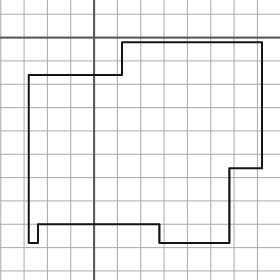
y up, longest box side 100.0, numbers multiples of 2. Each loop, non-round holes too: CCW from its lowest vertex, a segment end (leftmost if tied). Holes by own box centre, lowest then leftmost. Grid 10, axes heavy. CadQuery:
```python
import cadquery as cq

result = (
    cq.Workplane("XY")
    .moveTo(-28.0, -88.0)
    .lineTo(-24.0, -88.0)
    .lineTo(-24.0, -80.0)
    .lineTo(28.0, -80.0)
    .lineTo(28.0, -88.0)
    .lineTo(58.0, -88.0)
    .lineTo(58.0, -56.0)
    .lineTo(72.0, -56.0)
    .lineTo(72.0, -2.0)
    .lineTo(12.0, -2.0)
    .lineTo(12.0, -16.0)
    .lineTo(-28.0, -16.0)
    .close()
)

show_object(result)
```